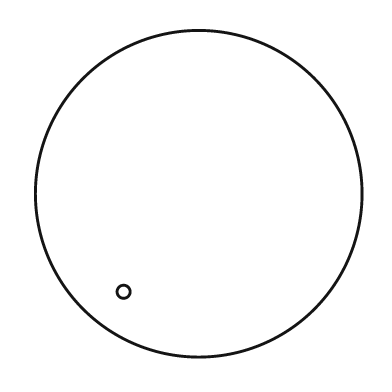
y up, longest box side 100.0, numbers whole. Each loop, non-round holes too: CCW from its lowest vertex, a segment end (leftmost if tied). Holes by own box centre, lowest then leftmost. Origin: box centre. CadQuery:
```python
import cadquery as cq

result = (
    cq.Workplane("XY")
    .moveTo(0.0, 0.0)
    .circle(50.0)
    .moveTo(-23.0, -30.0)
    .circle(2.0)
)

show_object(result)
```